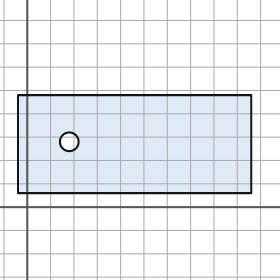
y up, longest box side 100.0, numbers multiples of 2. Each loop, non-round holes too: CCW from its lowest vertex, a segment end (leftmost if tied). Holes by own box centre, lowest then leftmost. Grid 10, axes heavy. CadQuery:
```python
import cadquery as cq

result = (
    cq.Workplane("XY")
    .moveTo(-4.0, 6.0)
    .lineTo(96.0, 6.0)
    .lineTo(96.0, 48.0)
    .lineTo(-4.0, 48.0)
    .close()
    .moveTo(18.0, 28.0)
    .circle(4.0)
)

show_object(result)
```